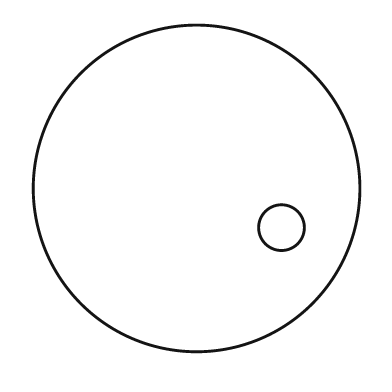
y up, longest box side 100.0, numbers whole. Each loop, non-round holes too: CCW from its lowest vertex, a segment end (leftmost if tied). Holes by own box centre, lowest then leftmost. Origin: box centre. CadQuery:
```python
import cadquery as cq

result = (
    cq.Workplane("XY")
    .moveTo(0.0, 0.0)
    .circle(50.0)
    .moveTo(26.0, -12.0)
    .circle(7.0)
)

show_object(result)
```